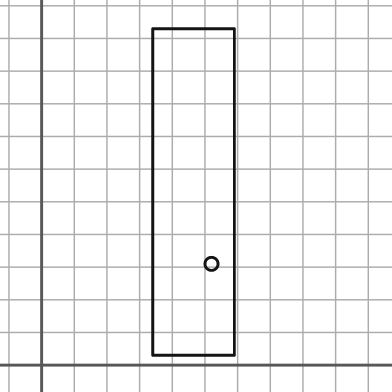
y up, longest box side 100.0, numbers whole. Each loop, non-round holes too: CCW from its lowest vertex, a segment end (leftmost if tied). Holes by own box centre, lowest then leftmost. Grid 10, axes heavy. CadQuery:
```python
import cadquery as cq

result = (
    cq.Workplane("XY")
    .moveTo(34.0, 3.0)
    .lineTo(59.0, 3.0)
    .lineTo(59.0, 103.0)
    .lineTo(34.0, 103.0)
    .close()
    .moveTo(52.0, 31.0)
    .circle(2.0)
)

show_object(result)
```